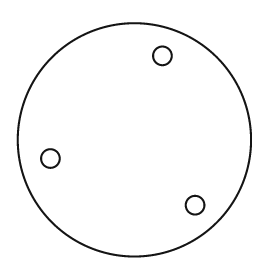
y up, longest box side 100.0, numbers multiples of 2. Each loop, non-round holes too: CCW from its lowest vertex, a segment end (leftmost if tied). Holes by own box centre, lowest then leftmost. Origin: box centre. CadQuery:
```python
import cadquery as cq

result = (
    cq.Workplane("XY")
    .moveTo(0.0, 0.0)
    .circle(50.0)
    .moveTo(26.0, -28.0)
    .circle(4.0)
    .moveTo(-36.0, -8.0)
    .circle(4.0)
    .moveTo(12.0, 36.0)
    .circle(4.0)
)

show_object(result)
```